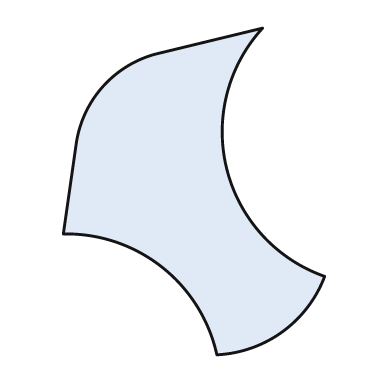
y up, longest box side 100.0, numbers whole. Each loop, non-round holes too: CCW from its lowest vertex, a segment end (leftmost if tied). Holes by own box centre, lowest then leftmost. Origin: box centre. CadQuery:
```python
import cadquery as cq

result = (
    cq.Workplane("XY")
    .moveTo(7.0, -50.0)
    .threePointArc((27.0, -43.0), (40.0, -26.0))
    .threePointArc((10.0, 7.0), (21.0, 50.0))
    .lineTo(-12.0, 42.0)
    .threePointArc((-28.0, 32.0), (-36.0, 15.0))
    .lineTo(-40.0, -13.0)
    .threePointArc((-10.0, -23.0), (7.0, -50.0))
    .close()
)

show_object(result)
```